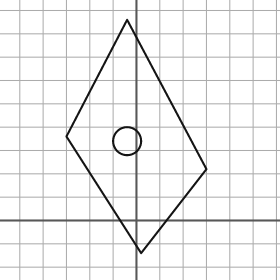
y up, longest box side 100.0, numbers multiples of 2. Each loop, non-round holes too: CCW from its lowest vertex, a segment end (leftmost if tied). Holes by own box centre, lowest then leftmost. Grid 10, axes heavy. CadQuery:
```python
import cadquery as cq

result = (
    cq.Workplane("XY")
    .moveTo(2.0, -14.0)
    .lineTo(30.0, 22.0)
    .lineTo(-4.0, 86.0)
    .lineTo(-30.0, 36.0)
    .close()
    .moveTo(-4.0, 34.0)
    .circle(6.0)
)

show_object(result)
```